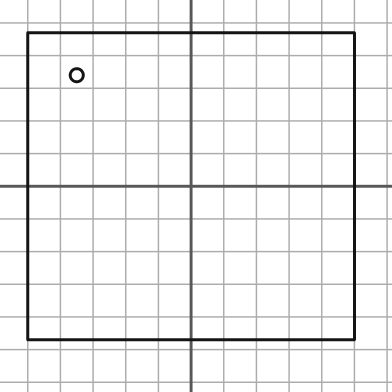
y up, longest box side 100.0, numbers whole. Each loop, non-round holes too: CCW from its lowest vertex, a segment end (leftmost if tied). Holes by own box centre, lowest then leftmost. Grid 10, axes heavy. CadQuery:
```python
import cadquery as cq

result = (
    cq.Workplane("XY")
    .moveTo(-50.0, -47.0)
    .lineTo(50.0, -47.0)
    .lineTo(50.0, 47.0)
    .lineTo(-50.0, 47.0)
    .close()
    .moveTo(-35.0, 34.0)
    .circle(2.0)
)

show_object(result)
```